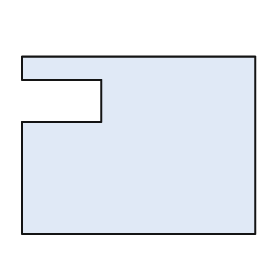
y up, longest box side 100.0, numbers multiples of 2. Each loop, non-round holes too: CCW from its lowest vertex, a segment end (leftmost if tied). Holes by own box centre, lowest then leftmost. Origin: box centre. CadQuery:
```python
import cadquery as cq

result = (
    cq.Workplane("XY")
    .moveTo(-50.0, -38.0)
    .lineTo(50.0, -38.0)
    .lineTo(50.0, 38.0)
    .lineTo(-50.0, 38.0)
    .lineTo(-50.0, 28.0)
    .lineTo(-16.0, 28.0)
    .lineTo(-16.0, 10.0)
    .lineTo(-50.0, 10.0)
    .close()
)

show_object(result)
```